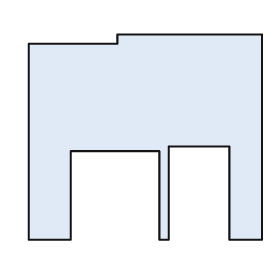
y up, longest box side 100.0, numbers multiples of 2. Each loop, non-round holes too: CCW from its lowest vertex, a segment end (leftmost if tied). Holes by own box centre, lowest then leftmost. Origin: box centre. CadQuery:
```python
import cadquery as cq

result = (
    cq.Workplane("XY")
    .moveTo(-50.0, -44.0)
    .lineTo(-32.0, -44.0)
    .lineTo(-32.0, -6.0)
    .lineTo(6.0, -6.0)
    .lineTo(6.0, -44.0)
    .lineTo(10.0, -44.0)
    .lineTo(10.0, -4.0)
    .lineTo(36.0, -4.0)
    .lineTo(36.0, -44.0)
    .lineTo(50.0, -44.0)
    .lineTo(50.0, 44.0)
    .lineTo(-12.0, 44.0)
    .lineTo(-12.0, 40.0)
    .lineTo(-50.0, 40.0)
    .close()
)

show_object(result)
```